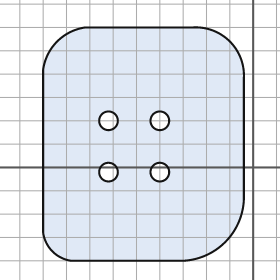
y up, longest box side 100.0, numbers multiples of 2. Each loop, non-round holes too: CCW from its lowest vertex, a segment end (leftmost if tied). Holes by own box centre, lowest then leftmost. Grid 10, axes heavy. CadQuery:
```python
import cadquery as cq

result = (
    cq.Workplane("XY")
    .moveTo(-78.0, -40.0)
    .lineTo(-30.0, -40.0)
    .threePointArc((-12.0, -32.0), (-4.0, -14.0))
    .lineTo(-4.0, 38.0)
    .threePointArc((-10.0, 54.0), (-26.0, 60.0))
    .lineTo(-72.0, 60.0)
    .threePointArc((-84.0, 54.0), (-90.0, 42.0))
    .lineTo(-90.0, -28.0)
    .threePointArc((-86.0, -36.0), (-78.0, -40.0))
    .close()
    .moveTo(-62.0, -2.0)
    .circle(4.0)
    .moveTo(-40.0, -2.0)
    .circle(4.0)
    .moveTo(-62.0, 20.0)
    .circle(4.0)
    .moveTo(-40.0, 20.0)
    .circle(4.0)
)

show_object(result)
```